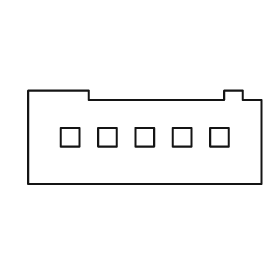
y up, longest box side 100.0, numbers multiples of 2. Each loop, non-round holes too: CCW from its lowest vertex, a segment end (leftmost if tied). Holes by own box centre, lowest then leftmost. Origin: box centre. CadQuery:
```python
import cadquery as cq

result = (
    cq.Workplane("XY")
    .moveTo(-50.0, -20.0)
    .lineTo(50.0, -20.0)
    .lineTo(50.0, 16.0)
    .lineTo(42.0, 16.0)
    .lineTo(42.0, 20.0)
    .lineTo(34.0, 20.0)
    .lineTo(34.0, 16.0)
    .lineTo(-24.0, 16.0)
    .lineTo(-24.0, 20.0)
    .lineTo(-50.0, 20.0)
    .close()
    .moveTo(-36.0, -4.0)
    .lineTo(-28.0, -4.0)
    .lineTo(-28.0, 4.0)
    .lineTo(-36.0, 4.0)
    .close()
    .moveTo(-20.0, -4.0)
    .lineTo(-12.0, -4.0)
    .lineTo(-12.0, 4.0)
    .lineTo(-20.0, 4.0)
    .close()
    .moveTo(-4.0, -4.0)
    .lineTo(4.0, -4.0)
    .lineTo(4.0, 4.0)
    .lineTo(-4.0, 4.0)
    .close()
    .moveTo(12.0, -4.0)
    .lineTo(20.0, -4.0)
    .lineTo(20.0, 4.0)
    .lineTo(12.0, 4.0)
    .close()
    .moveTo(28.0, -4.0)
    .lineTo(36.0, -4.0)
    .lineTo(36.0, 4.0)
    .lineTo(28.0, 4.0)
    .close()
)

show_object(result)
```